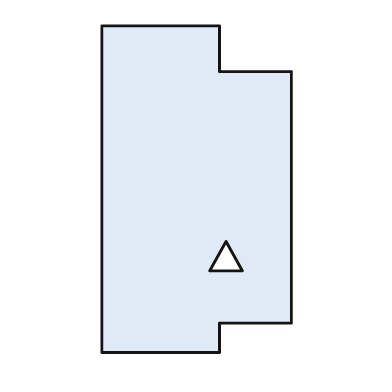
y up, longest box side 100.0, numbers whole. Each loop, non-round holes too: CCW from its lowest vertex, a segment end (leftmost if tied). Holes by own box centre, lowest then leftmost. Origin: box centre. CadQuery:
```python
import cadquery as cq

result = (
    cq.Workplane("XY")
    .moveTo(-29.0, -50.0)
    .lineTo(7.0, -50.0)
    .lineTo(7.0, -41.0)
    .lineTo(29.0, -41.0)
    .lineTo(29.0, 36.0)
    .lineTo(7.0, 36.0)
    .lineTo(7.0, 50.0)
    .lineTo(-29.0, 50.0)
    .close()
    .moveTo(4.0, -25.0)
    .lineTo(14.0, -25.0)
    .lineTo(9.0, -16.0)
    .close()
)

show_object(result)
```